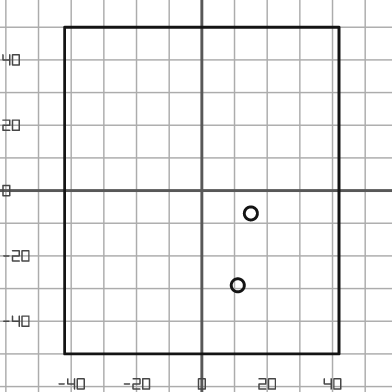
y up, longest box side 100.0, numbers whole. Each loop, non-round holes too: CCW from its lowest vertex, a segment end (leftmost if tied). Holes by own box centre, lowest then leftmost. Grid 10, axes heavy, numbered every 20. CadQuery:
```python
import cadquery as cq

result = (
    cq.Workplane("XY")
    .moveTo(-42.0, -50.0)
    .lineTo(42.0, -50.0)
    .lineTo(42.0, 50.0)
    .lineTo(-42.0, 50.0)
    .close()
    .moveTo(11.0, -29.0)
    .circle(2.0)
    .moveTo(15.0, -7.0)
    .circle(2.0)
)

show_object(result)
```